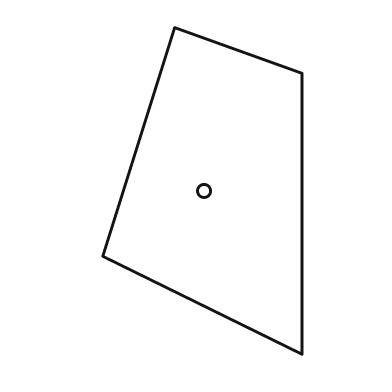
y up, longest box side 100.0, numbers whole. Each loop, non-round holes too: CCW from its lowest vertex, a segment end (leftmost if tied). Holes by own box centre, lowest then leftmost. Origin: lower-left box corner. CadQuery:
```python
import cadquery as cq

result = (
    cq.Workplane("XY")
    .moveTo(61.0, 0.0)
    .lineTo(61.0, 86.0)
    .lineTo(22.0, 100.0)
    .lineTo(0.0, 30.0)
    .close()
    .moveTo(31.0, 50.0)
    .circle(2.0)
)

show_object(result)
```